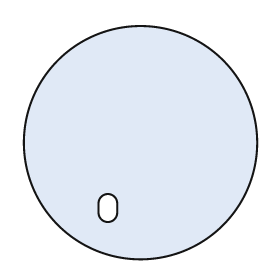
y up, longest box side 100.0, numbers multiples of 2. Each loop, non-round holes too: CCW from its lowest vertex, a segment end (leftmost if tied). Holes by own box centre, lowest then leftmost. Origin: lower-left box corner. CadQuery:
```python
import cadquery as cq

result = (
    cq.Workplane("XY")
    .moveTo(50.0, 50.0)
    .circle(50.0)
    .moveTo(32.0, 20.0)
    .threePointArc((36.0, 16.0), (40.0, 20.0))
    .lineTo(40.0, 24.0)
    .threePointArc((36.0, 28.0), (32.0, 24.0))
    .close()
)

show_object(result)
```